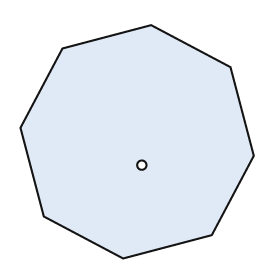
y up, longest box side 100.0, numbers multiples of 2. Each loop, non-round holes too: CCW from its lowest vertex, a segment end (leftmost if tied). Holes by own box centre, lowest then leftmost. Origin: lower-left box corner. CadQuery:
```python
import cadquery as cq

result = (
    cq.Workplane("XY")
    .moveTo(44.0, 0.0)
    .lineTo(82.0, 10.0)
    .lineTo(100.0, 44.0)
    .lineTo(90.0, 82.0)
    .lineTo(56.0, 100.0)
    .lineTo(18.0, 90.0)
    .lineTo(0.0, 56.0)
    .lineTo(10.0, 18.0)
    .close()
    .moveTo(52.0, 40.0)
    .circle(2.0)
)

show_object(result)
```